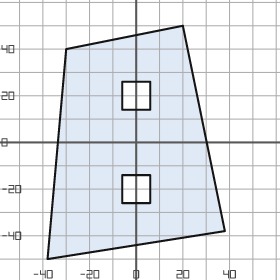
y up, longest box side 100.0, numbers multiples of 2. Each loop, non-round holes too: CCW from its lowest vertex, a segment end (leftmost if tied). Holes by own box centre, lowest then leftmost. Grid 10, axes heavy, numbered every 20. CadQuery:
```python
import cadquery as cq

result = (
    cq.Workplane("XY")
    .moveTo(-38.0, -50.0)
    .lineTo(38.0, -38.0)
    .lineTo(20.0, 50.0)
    .lineTo(-30.0, 40.0)
    .close()
    .moveTo(-6.0, -26.0)
    .lineTo(6.0, -26.0)
    .lineTo(6.0, -14.0)
    .lineTo(-6.0, -14.0)
    .close()
    .moveTo(-6.0, 14.0)
    .lineTo(6.0, 14.0)
    .lineTo(6.0, 26.0)
    .lineTo(-6.0, 26.0)
    .close()
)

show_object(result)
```